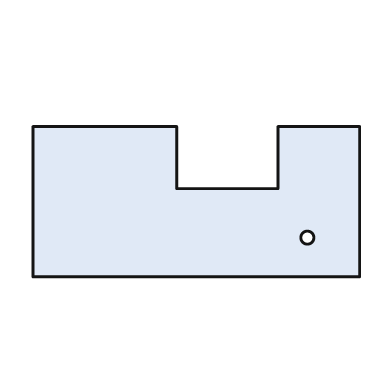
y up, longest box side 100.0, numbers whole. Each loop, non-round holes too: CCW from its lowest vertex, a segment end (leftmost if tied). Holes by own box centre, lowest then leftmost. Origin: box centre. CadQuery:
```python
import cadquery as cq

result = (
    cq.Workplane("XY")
    .moveTo(-50.0, -23.0)
    .lineTo(50.0, -23.0)
    .lineTo(50.0, 23.0)
    .lineTo(25.0, 23.0)
    .lineTo(25.0, 4.0)
    .lineTo(-6.0, 4.0)
    .lineTo(-6.0, 23.0)
    .lineTo(-50.0, 23.0)
    .close()
    .moveTo(34.0, -11.0)
    .circle(2.0)
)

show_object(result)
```